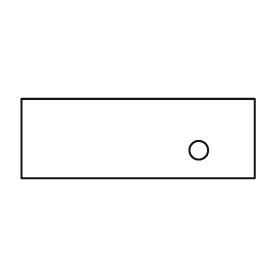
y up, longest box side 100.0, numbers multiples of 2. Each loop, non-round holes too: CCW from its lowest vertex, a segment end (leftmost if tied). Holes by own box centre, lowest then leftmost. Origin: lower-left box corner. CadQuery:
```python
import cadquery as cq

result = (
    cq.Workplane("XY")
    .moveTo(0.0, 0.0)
    .lineTo(100.0, 0.0)
    .lineTo(100.0, 34.0)
    .lineTo(0.0, 34.0)
    .close()
    .moveTo(76.0, 12.0)
    .circle(4.0)
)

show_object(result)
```